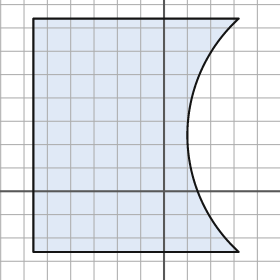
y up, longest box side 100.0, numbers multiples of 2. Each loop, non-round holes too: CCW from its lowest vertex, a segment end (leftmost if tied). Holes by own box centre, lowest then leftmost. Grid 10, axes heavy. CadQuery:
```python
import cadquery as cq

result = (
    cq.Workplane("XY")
    .moveTo(-56.0, -26.0)
    .lineTo(32.0, -26.0)
    .threePointArc((10.0, 24.0), (32.0, 74.0))
    .lineTo(-56.0, 74.0)
    .close()
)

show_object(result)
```